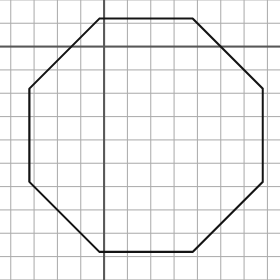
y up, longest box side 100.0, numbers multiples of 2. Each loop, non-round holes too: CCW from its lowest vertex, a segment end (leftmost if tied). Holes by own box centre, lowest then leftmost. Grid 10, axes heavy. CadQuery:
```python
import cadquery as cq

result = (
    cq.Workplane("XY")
    .moveTo(-2.0, -88.0)
    .lineTo(38.0, -88.0)
    .lineTo(68.0, -58.0)
    .lineTo(68.0, -18.0)
    .lineTo(38.0, 12.0)
    .lineTo(-2.0, 12.0)
    .lineTo(-32.0, -18.0)
    .lineTo(-32.0, -58.0)
    .close()
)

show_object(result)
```